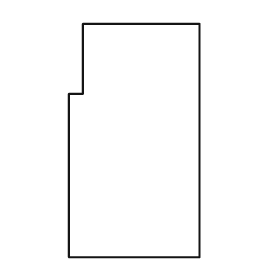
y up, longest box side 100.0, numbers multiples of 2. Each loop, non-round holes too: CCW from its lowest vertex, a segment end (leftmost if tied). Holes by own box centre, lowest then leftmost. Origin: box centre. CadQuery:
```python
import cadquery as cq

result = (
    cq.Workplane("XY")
    .moveTo(-28.0, -50.0)
    .lineTo(28.0, -50.0)
    .lineTo(28.0, 50.0)
    .lineTo(-22.0, 50.0)
    .lineTo(-22.0, 20.0)
    .lineTo(-28.0, 20.0)
    .close()
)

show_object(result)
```